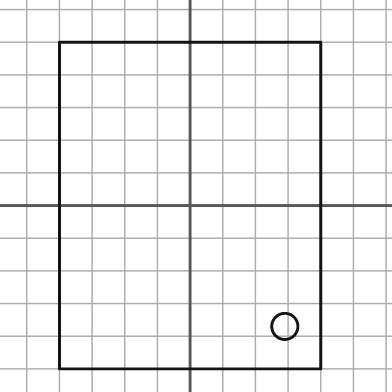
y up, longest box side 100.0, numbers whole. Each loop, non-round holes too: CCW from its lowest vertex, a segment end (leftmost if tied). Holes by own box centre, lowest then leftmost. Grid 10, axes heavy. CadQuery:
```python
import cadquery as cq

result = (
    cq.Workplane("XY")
    .moveTo(-40.0, -50.0)
    .lineTo(40.0, -50.0)
    .lineTo(40.0, 50.0)
    .lineTo(-40.0, 50.0)
    .close()
    .moveTo(29.0, -37.0)
    .circle(4.0)
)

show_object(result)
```